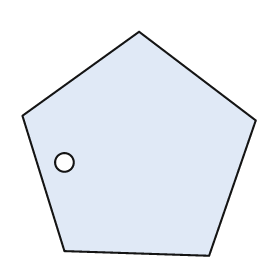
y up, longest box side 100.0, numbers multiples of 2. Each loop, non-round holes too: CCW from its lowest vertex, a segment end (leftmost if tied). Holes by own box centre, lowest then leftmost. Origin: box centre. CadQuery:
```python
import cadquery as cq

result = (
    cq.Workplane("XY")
    .moveTo(30.0, -48.0)
    .lineTo(50.0, 10.0)
    .lineTo(0.0, 48.0)
    .lineTo(-50.0, 12.0)
    .lineTo(-32.0, -46.0)
    .close()
    .moveTo(-32.0, -8.0)
    .circle(4.0)
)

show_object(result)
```